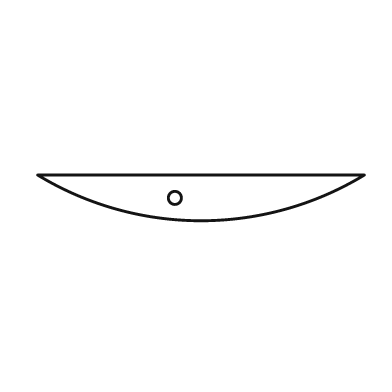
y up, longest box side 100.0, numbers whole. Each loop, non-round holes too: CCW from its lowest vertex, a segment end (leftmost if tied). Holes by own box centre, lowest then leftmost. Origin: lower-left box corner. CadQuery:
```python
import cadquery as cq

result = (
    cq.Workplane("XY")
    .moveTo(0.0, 14.0)
    .threePointArc((50.0, 0.0), (100.0, 14.0))
    .close()
    .moveTo(42.0, 7.0)
    .circle(2.0)
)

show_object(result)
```